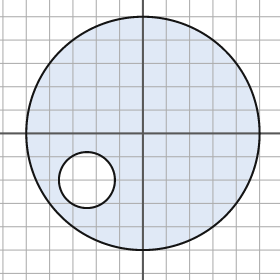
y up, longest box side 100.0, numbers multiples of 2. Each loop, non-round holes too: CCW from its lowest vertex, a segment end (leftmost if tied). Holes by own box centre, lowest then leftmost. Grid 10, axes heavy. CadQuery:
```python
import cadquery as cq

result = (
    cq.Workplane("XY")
    .moveTo(0.0, 0.0)
    .circle(50.0)
    .moveTo(-24.0, -20.0)
    .circle(12.0)
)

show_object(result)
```